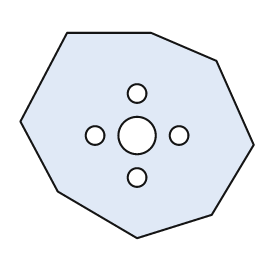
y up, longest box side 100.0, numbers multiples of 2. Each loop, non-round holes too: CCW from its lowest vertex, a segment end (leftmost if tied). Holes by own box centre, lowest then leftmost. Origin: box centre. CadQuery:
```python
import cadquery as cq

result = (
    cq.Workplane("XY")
    .moveTo(0.0, -44.0)
    .lineTo(32.0, -34.0)
    .lineTo(50.0, -4.0)
    .lineTo(34.0, 32.0)
    .lineTo(6.0, 44.0)
    .lineTo(-30.0, 44.0)
    .lineTo(-50.0, 6.0)
    .lineTo(-34.0, -24.0)
    .close()
    .moveTo(0.0, -18.0)
    .circle(4.0)
    .moveTo(-18.0, 0.0)
    .circle(4.0)
    .moveTo(0.0, 0.0)
    .circle(8.0)
    .moveTo(18.0, 0.0)
    .circle(4.0)
    .moveTo(0.0, 18.0)
    .circle(4.0)
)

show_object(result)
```